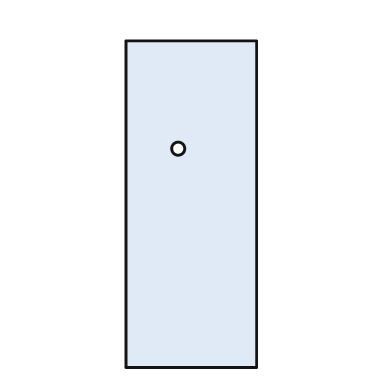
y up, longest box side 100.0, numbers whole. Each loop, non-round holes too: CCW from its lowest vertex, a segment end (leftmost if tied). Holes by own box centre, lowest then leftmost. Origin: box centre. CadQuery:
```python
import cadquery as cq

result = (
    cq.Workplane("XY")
    .moveTo(-20.0, -50.0)
    .lineTo(20.0, -50.0)
    .lineTo(20.0, 50.0)
    .lineTo(-20.0, 50.0)
    .close()
    .moveTo(-4.0, 17.0)
    .circle(2.0)
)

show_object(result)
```